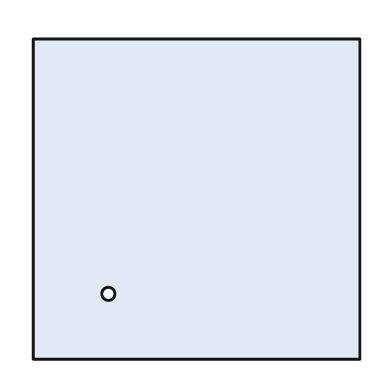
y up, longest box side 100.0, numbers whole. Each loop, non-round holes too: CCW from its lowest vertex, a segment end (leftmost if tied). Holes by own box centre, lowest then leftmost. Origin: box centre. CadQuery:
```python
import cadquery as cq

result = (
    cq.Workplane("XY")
    .moveTo(-50.0, -49.0)
    .lineTo(50.0, -49.0)
    .lineTo(50.0, 49.0)
    .lineTo(-50.0, 49.0)
    .close()
    .moveTo(-27.0, -29.0)
    .circle(2.0)
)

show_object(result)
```